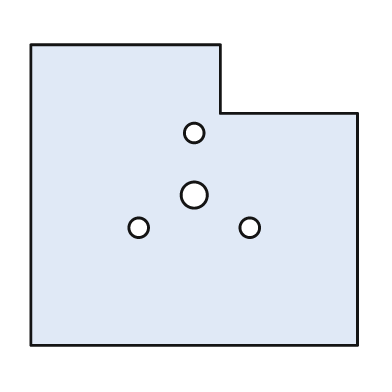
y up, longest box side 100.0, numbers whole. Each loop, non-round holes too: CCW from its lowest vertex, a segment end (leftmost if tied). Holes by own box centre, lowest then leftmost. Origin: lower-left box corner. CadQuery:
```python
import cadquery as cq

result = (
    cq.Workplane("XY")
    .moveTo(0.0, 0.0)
    .lineTo(100.0, 0.0)
    .lineTo(100.0, 71.0)
    .lineTo(58.0, 71.0)
    .lineTo(58.0, 92.0)
    .lineTo(0.0, 92.0)
    .close()
    .moveTo(33.0, 36.0)
    .circle(3.0)
    .moveTo(67.0, 36.0)
    .circle(3.0)
    .moveTo(50.0, 46.0)
    .circle(4.0)
    .moveTo(50.0, 65.0)
    .circle(3.0)
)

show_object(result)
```